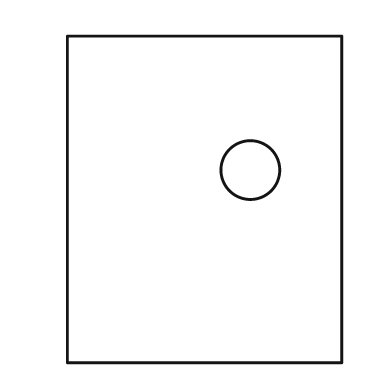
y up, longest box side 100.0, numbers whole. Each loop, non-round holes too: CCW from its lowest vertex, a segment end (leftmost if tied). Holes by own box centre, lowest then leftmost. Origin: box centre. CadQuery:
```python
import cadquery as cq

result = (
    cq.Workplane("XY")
    .moveTo(-42.0, -50.0)
    .lineTo(42.0, -50.0)
    .lineTo(42.0, 50.0)
    .lineTo(-42.0, 50.0)
    .close()
    .moveTo(14.0, 9.0)
    .circle(9.0)
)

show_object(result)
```